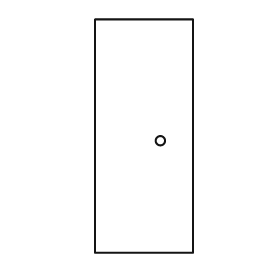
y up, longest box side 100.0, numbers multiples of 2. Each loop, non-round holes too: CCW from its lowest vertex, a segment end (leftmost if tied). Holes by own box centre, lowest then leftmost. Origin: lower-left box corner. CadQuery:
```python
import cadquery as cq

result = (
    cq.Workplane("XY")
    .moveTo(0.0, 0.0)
    .lineTo(42.0, 0.0)
    .lineTo(42.0, 100.0)
    .lineTo(0.0, 100.0)
    .close()
    .moveTo(28.0, 48.0)
    .circle(2.0)
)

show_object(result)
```